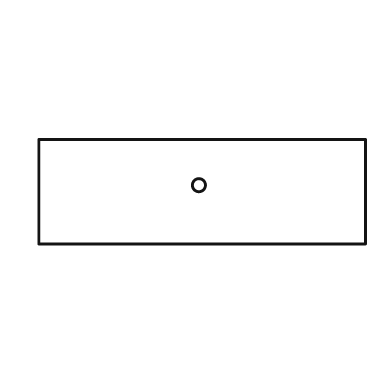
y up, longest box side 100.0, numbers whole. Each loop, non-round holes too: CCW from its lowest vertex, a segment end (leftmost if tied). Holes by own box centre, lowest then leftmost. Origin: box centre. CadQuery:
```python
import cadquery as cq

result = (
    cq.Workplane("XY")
    .moveTo(-50.0, -16.0)
    .lineTo(50.0, -16.0)
    .lineTo(50.0, 16.0)
    .lineTo(-50.0, 16.0)
    .close()
    .moveTo(-1.0, 2.0)
    .circle(2.0)
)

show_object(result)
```